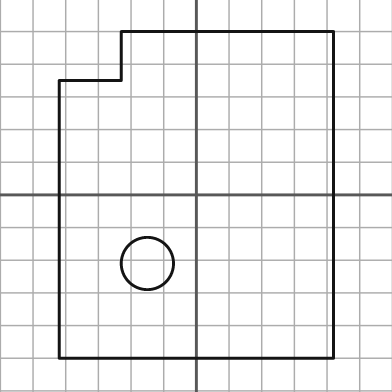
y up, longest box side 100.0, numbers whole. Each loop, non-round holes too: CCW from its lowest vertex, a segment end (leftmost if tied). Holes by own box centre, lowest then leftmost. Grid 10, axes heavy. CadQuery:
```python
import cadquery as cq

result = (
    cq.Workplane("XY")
    .moveTo(-42.0, -50.0)
    .lineTo(42.0, -50.0)
    .lineTo(42.0, 50.0)
    .lineTo(-23.0, 50.0)
    .lineTo(-23.0, 35.0)
    .lineTo(-42.0, 35.0)
    .close()
    .moveTo(-15.0, -21.0)
    .circle(8.0)
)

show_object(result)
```